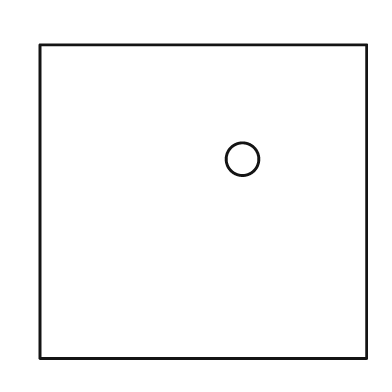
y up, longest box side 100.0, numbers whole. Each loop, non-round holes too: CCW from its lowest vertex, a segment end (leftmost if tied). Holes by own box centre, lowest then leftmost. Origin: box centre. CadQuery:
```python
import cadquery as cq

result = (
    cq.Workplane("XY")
    .moveTo(-50.0, -48.0)
    .lineTo(50.0, -48.0)
    .lineTo(50.0, 48.0)
    .lineTo(-50.0, 48.0)
    .close()
    .moveTo(12.0, 13.0)
    .circle(5.0)
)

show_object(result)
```